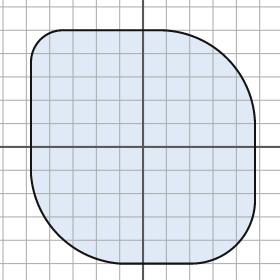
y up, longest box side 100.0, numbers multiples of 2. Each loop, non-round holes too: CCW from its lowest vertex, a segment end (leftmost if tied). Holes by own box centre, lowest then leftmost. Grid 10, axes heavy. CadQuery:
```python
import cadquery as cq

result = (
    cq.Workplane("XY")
    .moveTo(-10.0, -50.0)
    .lineTo(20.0, -50.0)
    .threePointArc((40.0, -42.0), (48.0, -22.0))
    .lineTo(48.0, 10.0)
    .threePointArc((36.0, 38.0), (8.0, 50.0))
    .lineTo(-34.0, 50.0)
    .threePointArc((-44.0, 46.0), (-48.0, 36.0))
    .lineTo(-48.0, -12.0)
    .threePointArc((-36.0, -38.0), (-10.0, -50.0))
    .close()
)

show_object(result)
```